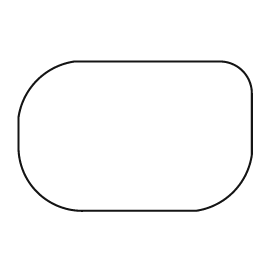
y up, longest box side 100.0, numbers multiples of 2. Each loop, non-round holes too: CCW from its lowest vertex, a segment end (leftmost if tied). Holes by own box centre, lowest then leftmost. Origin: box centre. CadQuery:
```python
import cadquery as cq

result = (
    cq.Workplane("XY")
    .moveTo(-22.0, -32.0)
    .lineTo(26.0, -32.0)
    .threePointArc((42.0, -24.0), (50.0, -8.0))
    .lineTo(50.0, 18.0)
    .threePointArc((46.0, 28.0), (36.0, 32.0))
    .lineTo(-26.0, 32.0)
    .threePointArc((-42.0, 24.0), (-50.0, 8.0))
    .lineTo(-50.0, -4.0)
    .threePointArc((-42.0, -24.0), (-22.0, -32.0))
    .close()
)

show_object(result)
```